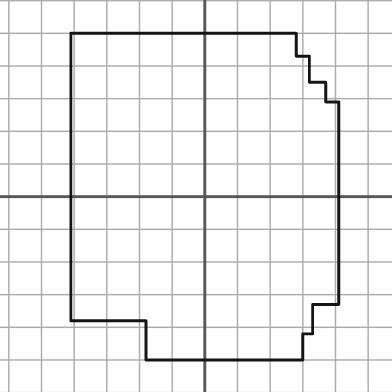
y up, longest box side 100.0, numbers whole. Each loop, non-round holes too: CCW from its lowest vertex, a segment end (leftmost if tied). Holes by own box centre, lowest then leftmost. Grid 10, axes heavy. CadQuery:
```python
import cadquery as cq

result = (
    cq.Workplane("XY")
    .moveTo(-18.0, -50.0)
    .lineTo(30.0, -50.0)
    .lineTo(30.0, -42.0)
    .lineTo(33.0, -42.0)
    .lineTo(33.0, -33.0)
    .lineTo(41.0, -33.0)
    .lineTo(41.0, 29.0)
    .lineTo(37.0, 29.0)
    .lineTo(37.0, 35.0)
    .lineTo(32.0, 35.0)
    .lineTo(32.0, 43.0)
    .lineTo(28.0, 43.0)
    .lineTo(28.0, 50.0)
    .lineTo(-41.0, 50.0)
    .lineTo(-41.0, -38.0)
    .lineTo(-18.0, -38.0)
    .close()
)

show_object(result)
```